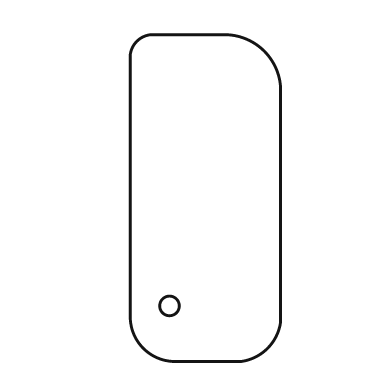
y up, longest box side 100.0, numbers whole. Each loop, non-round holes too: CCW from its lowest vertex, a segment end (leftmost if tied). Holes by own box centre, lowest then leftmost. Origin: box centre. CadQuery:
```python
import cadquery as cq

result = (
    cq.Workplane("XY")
    .moveTo(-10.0, -50.0)
    .lineTo(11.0, -50.0)
    .threePointArc((19.0, -46.0), (23.0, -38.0))
    .lineTo(23.0, 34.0)
    .threePointArc((18.0, 45.0), (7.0, 50.0))
    .lineTo(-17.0, 50.0)
    .threePointArc((-21.0, 48.0), (-23.0, 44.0))
    .lineTo(-23.0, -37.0)
    .threePointArc((-19.0, -46.0), (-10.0, -50.0))
    .close()
    .moveTo(-11.0, -33.0)
    .circle(3.0)
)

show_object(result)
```